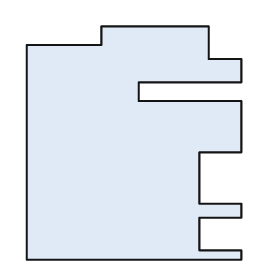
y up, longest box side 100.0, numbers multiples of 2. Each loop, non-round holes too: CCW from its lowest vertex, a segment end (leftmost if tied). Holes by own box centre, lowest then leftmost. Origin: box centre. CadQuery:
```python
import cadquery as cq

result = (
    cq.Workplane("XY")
    .moveTo(-46.0, -50.0)
    .lineTo(46.0, -50.0)
    .lineTo(46.0, -46.0)
    .lineTo(28.0, -46.0)
    .lineTo(28.0, -32.0)
    .lineTo(46.0, -32.0)
    .lineTo(46.0, -26.0)
    .lineTo(28.0, -26.0)
    .lineTo(28.0, -4.0)
    .lineTo(46.0, -4.0)
    .lineTo(46.0, 18.0)
    .lineTo(2.0, 18.0)
    .lineTo(2.0, 26.0)
    .lineTo(46.0, 26.0)
    .lineTo(46.0, 36.0)
    .lineTo(32.0, 36.0)
    .lineTo(32.0, 50.0)
    .lineTo(-14.0, 50.0)
    .lineTo(-14.0, 42.0)
    .lineTo(-46.0, 42.0)
    .close()
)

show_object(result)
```